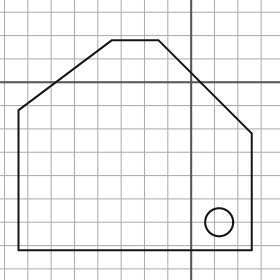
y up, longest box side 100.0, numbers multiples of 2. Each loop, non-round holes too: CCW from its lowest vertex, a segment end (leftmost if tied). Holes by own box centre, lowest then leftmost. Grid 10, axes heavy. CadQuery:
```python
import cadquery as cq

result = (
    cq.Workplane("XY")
    .moveTo(-74.0, -72.0)
    .lineTo(26.0, -72.0)
    .lineTo(26.0, -22.0)
    .lineTo(-14.0, 18.0)
    .lineTo(-34.0, 18.0)
    .lineTo(-74.0, -12.0)
    .close()
    .moveTo(12.0, -60.0)
    .circle(6.0)
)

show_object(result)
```